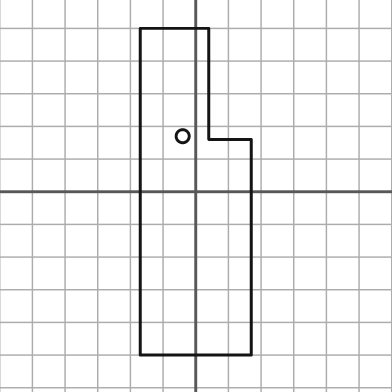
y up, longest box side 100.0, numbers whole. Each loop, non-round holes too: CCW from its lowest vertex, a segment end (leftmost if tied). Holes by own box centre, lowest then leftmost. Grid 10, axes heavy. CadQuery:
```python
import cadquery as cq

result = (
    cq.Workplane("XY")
    .moveTo(-17.0, -50.0)
    .lineTo(17.0, -50.0)
    .lineTo(17.0, 16.0)
    .lineTo(4.0, 16.0)
    .lineTo(4.0, 50.0)
    .lineTo(-17.0, 50.0)
    .close()
    .moveTo(-4.0, 17.0)
    .circle(2.0)
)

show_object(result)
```